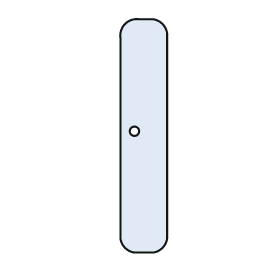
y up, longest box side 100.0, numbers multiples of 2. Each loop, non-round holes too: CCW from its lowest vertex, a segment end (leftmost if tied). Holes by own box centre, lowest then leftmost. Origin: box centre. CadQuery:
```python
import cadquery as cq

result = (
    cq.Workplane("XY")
    .moveTo(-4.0, -50.0)
    .lineTo(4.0, -50.0)
    .threePointArc((8.0, -48.0), (10.0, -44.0))
    .lineTo(10.0, 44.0)
    .threePointArc((8.0, 48.0), (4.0, 50.0))
    .lineTo(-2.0, 50.0)
    .threePointArc((-8.0, 48.0), (-10.0, 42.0))
    .lineTo(-10.0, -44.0)
    .threePointArc((-8.0, -48.0), (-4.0, -50.0))
    .close()
    .moveTo(-4.0, 2.0)
    .circle(2.0)
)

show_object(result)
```